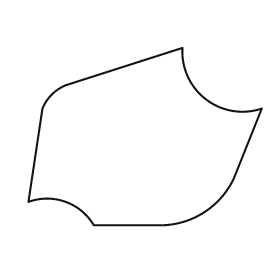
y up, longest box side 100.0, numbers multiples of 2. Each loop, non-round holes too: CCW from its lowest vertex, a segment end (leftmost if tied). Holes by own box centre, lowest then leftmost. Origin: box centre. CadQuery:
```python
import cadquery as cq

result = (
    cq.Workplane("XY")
    .moveTo(-22.0, -38.0)
    .lineTo(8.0, -38.0)
    .threePointArc((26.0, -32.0), (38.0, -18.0))
    .lineTo(50.0, 12.0)
    .threePointArc((26.0, 16.0), (16.0, 38.0))
    .lineTo(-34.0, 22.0)
    .threePointArc((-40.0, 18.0), (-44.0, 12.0))
    .lineTo(-50.0, -28.0)
    .threePointArc((-34.0, -28.0), (-22.0, -38.0))
    .close()
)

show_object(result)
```